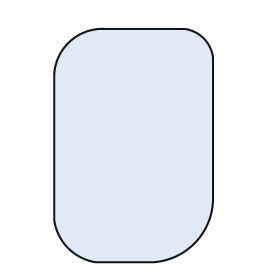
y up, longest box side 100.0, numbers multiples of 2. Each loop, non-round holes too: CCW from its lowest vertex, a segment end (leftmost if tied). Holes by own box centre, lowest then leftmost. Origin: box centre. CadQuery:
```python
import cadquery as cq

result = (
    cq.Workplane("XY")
    .moveTo(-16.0, -50.0)
    .lineTo(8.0, -50.0)
    .threePointArc((26.0, -42.0), (34.0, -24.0))
    .lineTo(34.0, 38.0)
    .threePointArc((30.0, 46.0), (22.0, 50.0))
    .lineTo(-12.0, 50.0)
    .threePointArc((-28.0, 44.0), (-34.0, 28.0))
    .lineTo(-34.0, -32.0)
    .threePointArc((-28.0, -44.0), (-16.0, -50.0))
    .close()
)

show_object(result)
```